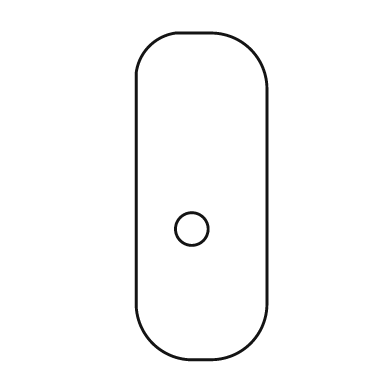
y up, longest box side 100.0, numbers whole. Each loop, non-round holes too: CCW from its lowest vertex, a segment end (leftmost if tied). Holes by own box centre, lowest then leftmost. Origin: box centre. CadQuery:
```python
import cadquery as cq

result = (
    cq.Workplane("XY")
    .moveTo(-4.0, -50.0)
    .lineTo(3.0, -50.0)
    .threePointArc((15.0, -45.0), (20.0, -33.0))
    .lineTo(20.0, 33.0)
    .threePointArc((15.0, 45.0), (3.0, 50.0))
    .lineTo(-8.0, 50.0)
    .threePointArc((-16.0, 46.0), (-20.0, 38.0))
    .lineTo(-20.0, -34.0)
    .threePointArc((-15.0, -45.0), (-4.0, -50.0))
    .close()
    .moveTo(-3.0, -10.0)
    .circle(5.0)
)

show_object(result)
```